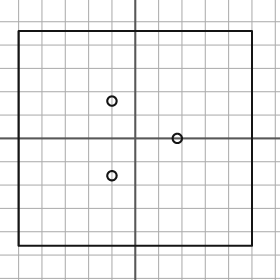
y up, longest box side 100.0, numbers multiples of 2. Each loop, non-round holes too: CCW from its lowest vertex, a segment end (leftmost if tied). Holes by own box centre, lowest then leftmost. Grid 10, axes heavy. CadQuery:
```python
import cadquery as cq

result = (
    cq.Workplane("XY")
    .moveTo(-50.0, -46.0)
    .lineTo(50.0, -46.0)
    .lineTo(50.0, 46.0)
    .lineTo(-50.0, 46.0)
    .close()
    .moveTo(-10.0, -16.0)
    .circle(2.0)
    .moveTo(18.0, 0.0)
    .circle(2.0)
    .moveTo(-10.0, 16.0)
    .circle(2.0)
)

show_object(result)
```